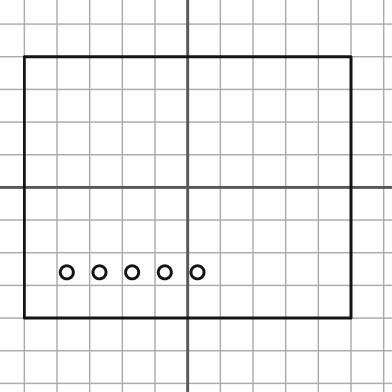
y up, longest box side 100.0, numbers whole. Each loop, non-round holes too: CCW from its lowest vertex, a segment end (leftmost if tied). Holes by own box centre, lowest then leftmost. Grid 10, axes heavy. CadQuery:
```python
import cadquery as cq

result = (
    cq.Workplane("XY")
    .moveTo(-50.0, -40.0)
    .lineTo(50.0, -40.0)
    .lineTo(50.0, 40.0)
    .lineTo(-50.0, 40.0)
    .close()
    .moveTo(-37.0, -26.0)
    .circle(2.0)
    .moveTo(-27.0, -26.0)
    .circle(2.0)
    .moveTo(-17.0, -26.0)
    .circle(2.0)
    .moveTo(-7.0, -26.0)
    .circle(2.0)
    .moveTo(3.0, -26.0)
    .circle(2.0)
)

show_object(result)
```